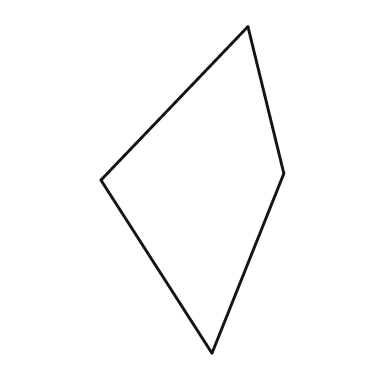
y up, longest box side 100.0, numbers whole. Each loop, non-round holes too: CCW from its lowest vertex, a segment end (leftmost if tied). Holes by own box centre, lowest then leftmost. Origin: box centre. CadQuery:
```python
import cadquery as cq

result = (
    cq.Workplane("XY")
    .moveTo(6.0, -50.0)
    .lineTo(28.0, 5.0)
    .lineTo(17.0, 50.0)
    .lineTo(-28.0, 3.0)
    .close()
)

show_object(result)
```